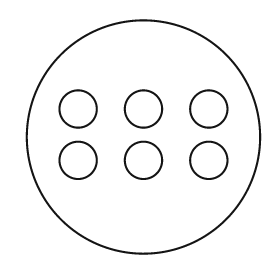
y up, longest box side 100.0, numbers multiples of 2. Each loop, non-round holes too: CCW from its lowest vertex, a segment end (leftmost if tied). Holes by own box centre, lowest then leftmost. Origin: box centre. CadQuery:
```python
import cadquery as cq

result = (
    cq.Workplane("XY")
    .moveTo(0.0, 0.0)
    .circle(50.0)
    .moveTo(-28.0, -10.0)
    .circle(8.0)
    .moveTo(0.0, -10.0)
    .circle(8.0)
    .moveTo(28.0, -10.0)
    .circle(8.0)
    .moveTo(-28.0, 12.0)
    .circle(8.0)
    .moveTo(0.0, 12.0)
    .circle(8.0)
    .moveTo(28.0, 12.0)
    .circle(8.0)
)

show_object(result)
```